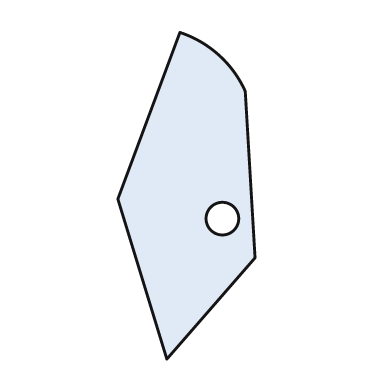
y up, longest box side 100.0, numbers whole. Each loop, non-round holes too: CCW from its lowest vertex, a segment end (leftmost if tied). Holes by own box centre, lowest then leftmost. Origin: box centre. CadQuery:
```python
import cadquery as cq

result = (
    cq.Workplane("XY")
    .moveTo(-6.0, -50.0)
    .lineTo(21.0, -19.0)
    .lineTo(18.0, 32.0)
    .threePointArc((10.0, 43.0), (-2.0, 50.0))
    .lineTo(-21.0, -1.0)
    .close()
    .moveTo(11.0, -7.0)
    .circle(5.0)
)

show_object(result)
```